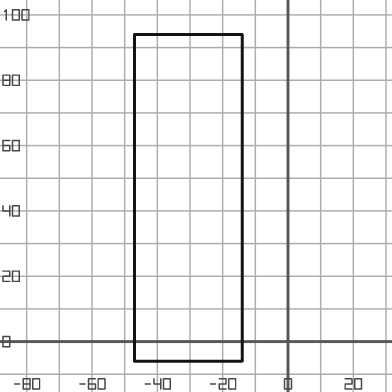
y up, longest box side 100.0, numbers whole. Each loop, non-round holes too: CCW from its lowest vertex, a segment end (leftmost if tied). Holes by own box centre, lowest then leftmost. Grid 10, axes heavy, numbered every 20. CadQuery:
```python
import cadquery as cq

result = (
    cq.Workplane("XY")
    .moveTo(-47.0, -6.0)
    .lineTo(-14.0, -6.0)
    .lineTo(-14.0, 94.0)
    .lineTo(-47.0, 94.0)
    .close()
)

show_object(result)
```